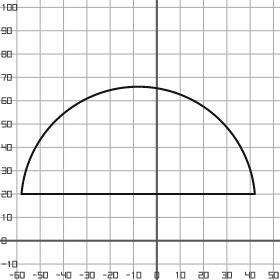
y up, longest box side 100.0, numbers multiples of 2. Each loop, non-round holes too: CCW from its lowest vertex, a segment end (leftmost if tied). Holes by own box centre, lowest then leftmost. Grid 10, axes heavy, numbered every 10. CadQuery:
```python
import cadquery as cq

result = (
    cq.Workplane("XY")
    .moveTo(-58.0, 20.0)
    .lineTo(42.0, 20.0)
    .threePointArc((-8.0, 66.0), (-58.0, 20.0))
    .close()
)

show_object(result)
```